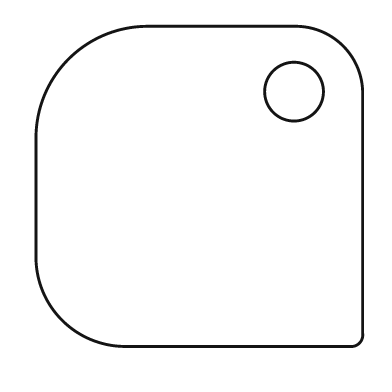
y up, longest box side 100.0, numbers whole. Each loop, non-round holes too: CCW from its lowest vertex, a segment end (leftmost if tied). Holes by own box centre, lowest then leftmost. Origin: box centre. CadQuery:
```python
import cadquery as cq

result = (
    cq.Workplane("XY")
    .moveTo(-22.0, -49.0)
    .lineTo(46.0, -49.0)
    .threePointArc((49.0, -48.0), (50.0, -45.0))
    .lineTo(50.0, 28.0)
    .threePointArc((44.0, 43.0), (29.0, 49.0))
    .lineTo(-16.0, 49.0)
    .threePointArc((-40.0, 39.0), (-50.0, 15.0))
    .lineTo(-50.0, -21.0)
    .threePointArc((-42.0, -41.0), (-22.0, -49.0))
    .close()
    .moveTo(29.0, 29.0)
    .circle(9.0)
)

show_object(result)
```